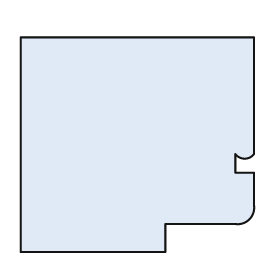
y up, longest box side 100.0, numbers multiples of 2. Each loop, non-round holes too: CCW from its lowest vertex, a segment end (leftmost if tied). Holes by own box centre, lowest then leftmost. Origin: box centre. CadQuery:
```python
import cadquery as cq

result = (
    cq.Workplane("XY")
    .moveTo(-50.0, -46.0)
    .lineTo(12.0, -46.0)
    .lineTo(12.0, -34.0)
    .lineTo(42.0, -34.0)
    .threePointArc((48.0, -32.0), (50.0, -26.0))
    .lineTo(50.0, -12.0)
    .lineTo(42.0, -12.0)
    .lineTo(42.0, -4.0)
    .threePointArc((46.0, -6.0), (50.0, -4.0))
    .lineTo(50.0, 46.0)
    .lineTo(-50.0, 46.0)
    .close()
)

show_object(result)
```